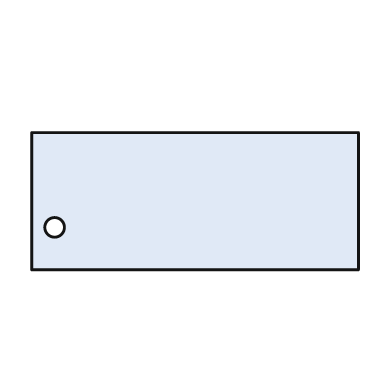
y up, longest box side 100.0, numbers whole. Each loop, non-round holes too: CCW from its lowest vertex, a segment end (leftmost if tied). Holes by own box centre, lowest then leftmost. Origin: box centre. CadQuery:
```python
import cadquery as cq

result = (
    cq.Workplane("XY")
    .moveTo(-50.0, -21.0)
    .lineTo(50.0, -21.0)
    .lineTo(50.0, 21.0)
    .lineTo(-50.0, 21.0)
    .close()
    .moveTo(-43.0, -8.0)
    .circle(3.0)
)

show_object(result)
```